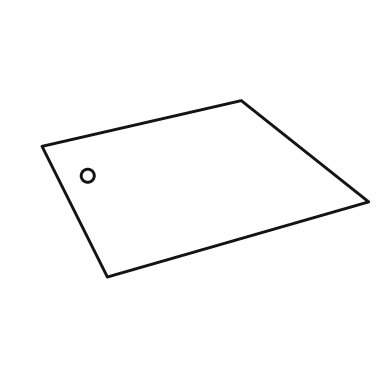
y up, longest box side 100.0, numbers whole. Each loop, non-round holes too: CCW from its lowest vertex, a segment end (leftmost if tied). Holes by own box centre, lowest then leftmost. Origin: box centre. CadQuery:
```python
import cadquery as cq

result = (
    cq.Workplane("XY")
    .moveTo(-30.0, -27.0)
    .lineTo(50.0, -4.0)
    .lineTo(11.0, 27.0)
    .lineTo(-50.0, 13.0)
    .close()
    .moveTo(-36.0, 4.0)
    .circle(2.0)
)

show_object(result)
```